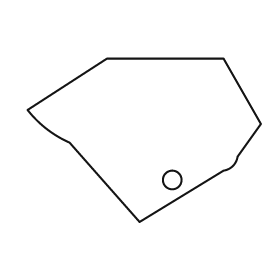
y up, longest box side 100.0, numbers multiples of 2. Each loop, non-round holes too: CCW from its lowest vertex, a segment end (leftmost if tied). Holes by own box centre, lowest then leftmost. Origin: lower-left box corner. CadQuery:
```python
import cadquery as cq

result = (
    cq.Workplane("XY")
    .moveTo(48.0, 0.0)
    .lineTo(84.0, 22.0)
    .threePointArc((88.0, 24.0), (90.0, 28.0))
    .lineTo(100.0, 42.0)
    .lineTo(84.0, 70.0)
    .lineTo(34.0, 70.0)
    .lineTo(0.0, 48.0)
    .threePointArc((8.0, 40.0), (18.0, 34.0))
    .close()
    .moveTo(62.0, 18.0)
    .circle(4.0)
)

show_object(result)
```